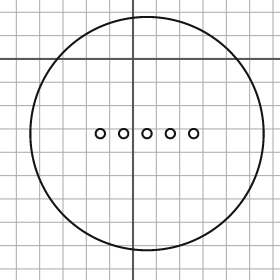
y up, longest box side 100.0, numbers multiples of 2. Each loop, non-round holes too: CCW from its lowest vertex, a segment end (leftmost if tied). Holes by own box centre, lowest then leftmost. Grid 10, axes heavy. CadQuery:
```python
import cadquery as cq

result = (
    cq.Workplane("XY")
    .moveTo(6.0, -32.0)
    .circle(50.0)
    .moveTo(-14.0, -32.0)
    .circle(2.0)
    .moveTo(-4.0, -32.0)
    .circle(2.0)
    .moveTo(6.0, -32.0)
    .circle(2.0)
    .moveTo(16.0, -32.0)
    .circle(2.0)
    .moveTo(26.0, -32.0)
    .circle(2.0)
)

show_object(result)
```